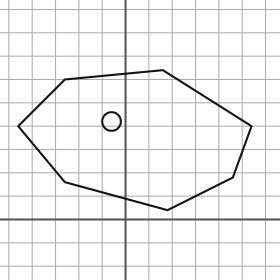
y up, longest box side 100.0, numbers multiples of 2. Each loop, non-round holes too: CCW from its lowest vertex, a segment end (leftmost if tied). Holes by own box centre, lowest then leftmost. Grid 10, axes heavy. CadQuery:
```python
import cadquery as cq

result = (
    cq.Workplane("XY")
    .moveTo(18.0, 4.0)
    .lineTo(46.0, 18.0)
    .lineTo(54.0, 40.0)
    .lineTo(16.0, 64.0)
    .lineTo(-26.0, 60.0)
    .lineTo(-46.0, 40.0)
    .lineTo(-26.0, 16.0)
    .close()
    .moveTo(-6.0, 42.0)
    .circle(4.0)
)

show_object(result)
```